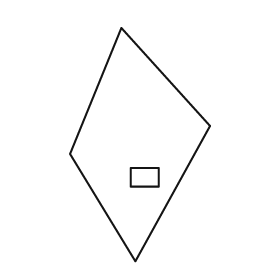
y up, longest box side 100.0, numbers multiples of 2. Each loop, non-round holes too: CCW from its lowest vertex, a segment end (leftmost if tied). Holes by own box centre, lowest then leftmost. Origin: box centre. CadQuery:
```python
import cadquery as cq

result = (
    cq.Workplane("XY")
    .moveTo(-2.0, -50.0)
    .lineTo(30.0, 8.0)
    .lineTo(-8.0, 50.0)
    .lineTo(-30.0, -4.0)
    .close()
    .moveTo(-4.0, -18.0)
    .lineTo(8.0, -18.0)
    .lineTo(8.0, -10.0)
    .lineTo(-4.0, -10.0)
    .close()
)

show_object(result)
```